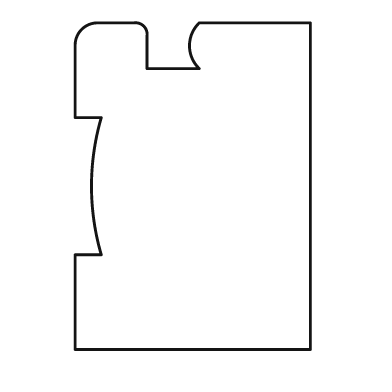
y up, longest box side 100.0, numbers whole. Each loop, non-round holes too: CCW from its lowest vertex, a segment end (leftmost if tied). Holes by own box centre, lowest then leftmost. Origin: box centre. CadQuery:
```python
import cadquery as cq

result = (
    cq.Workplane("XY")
    .moveTo(-36.0, -50.0)
    .lineTo(36.0, -50.0)
    .lineTo(36.0, 50.0)
    .lineTo(2.0, 50.0)
    .threePointArc((-1.0, 43.0), (2.0, 36.0))
    .lineTo(-14.0, 36.0)
    .lineTo(-14.0, 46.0)
    .threePointArc((-15.0, 49.0), (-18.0, 50.0))
    .lineTo(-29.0, 50.0)
    .threePointArc((-34.0, 48.0), (-36.0, 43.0))
    .lineTo(-36.0, 21.0)
    .lineTo(-28.0, 21.0)
    .threePointArc((-31.0, 0.0), (-28.0, -21.0))
    .lineTo(-36.0, -21.0)
    .close()
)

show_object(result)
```